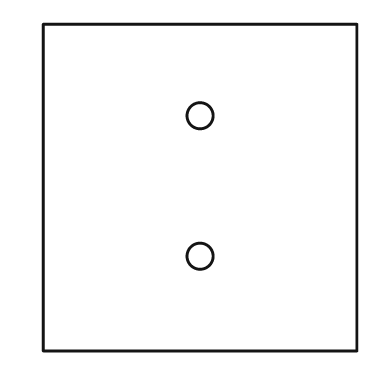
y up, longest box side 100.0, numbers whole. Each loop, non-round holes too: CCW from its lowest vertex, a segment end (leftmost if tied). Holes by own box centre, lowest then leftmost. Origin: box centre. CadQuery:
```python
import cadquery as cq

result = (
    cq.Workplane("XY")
    .moveTo(-48.0, -50.0)
    .lineTo(48.0, -50.0)
    .lineTo(48.0, 50.0)
    .lineTo(-48.0, 50.0)
    .close()
    .moveTo(0.0, -21.0)
    .circle(4.0)
    .moveTo(0.0, 22.0)
    .circle(4.0)
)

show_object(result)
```